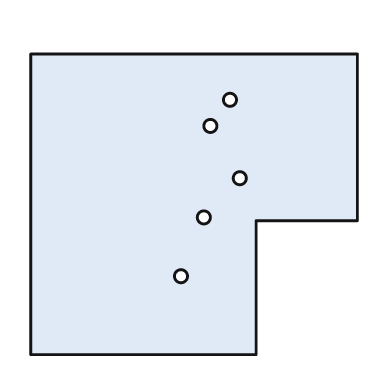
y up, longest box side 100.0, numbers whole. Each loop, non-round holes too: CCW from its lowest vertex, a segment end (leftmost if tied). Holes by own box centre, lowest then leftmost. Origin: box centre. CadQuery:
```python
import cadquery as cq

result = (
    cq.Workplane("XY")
    .moveTo(-50.0, -46.0)
    .lineTo(19.0, -46.0)
    .lineTo(19.0, -5.0)
    .lineTo(50.0, -5.0)
    .lineTo(50.0, 46.0)
    .lineTo(-50.0, 46.0)
    .close()
    .moveTo(-4.0, -22.0)
    .circle(2.0)
    .moveTo(3.0, -4.0)
    .circle(2.0)
    .moveTo(14.0, 8.0)
    .circle(2.0)
    .moveTo(5.0, 24.0)
    .circle(2.0)
    .moveTo(11.0, 32.0)
    .circle(2.0)
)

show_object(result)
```